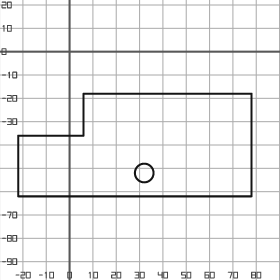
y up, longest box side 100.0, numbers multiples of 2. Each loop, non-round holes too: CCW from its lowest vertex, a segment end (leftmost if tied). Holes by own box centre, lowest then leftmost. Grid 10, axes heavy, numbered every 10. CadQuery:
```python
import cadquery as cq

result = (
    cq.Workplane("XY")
    .moveTo(-22.0, -62.0)
    .lineTo(78.0, -62.0)
    .lineTo(78.0, -18.0)
    .lineTo(6.0, -18.0)
    .lineTo(6.0, -36.0)
    .lineTo(-22.0, -36.0)
    .close()
    .moveTo(32.0, -52.0)
    .circle(4.0)
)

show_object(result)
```